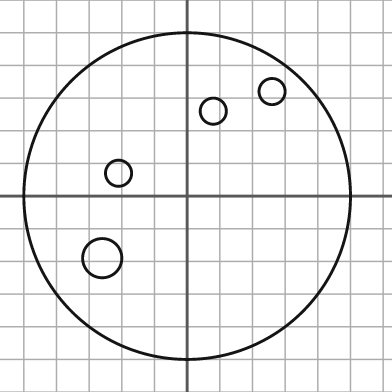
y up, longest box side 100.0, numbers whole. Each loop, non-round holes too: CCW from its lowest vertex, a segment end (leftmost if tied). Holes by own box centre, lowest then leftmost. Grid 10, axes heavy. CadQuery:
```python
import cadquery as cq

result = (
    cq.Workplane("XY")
    .moveTo(0.0, 0.0)
    .circle(50.0)
    .moveTo(-26.0, -19.0)
    .circle(6.0)
    .moveTo(-21.0, 7.0)
    .circle(4.0)
    .moveTo(8.0, 26.0)
    .circle(4.0)
    .moveTo(26.0, 32.0)
    .circle(4.0)
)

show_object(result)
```